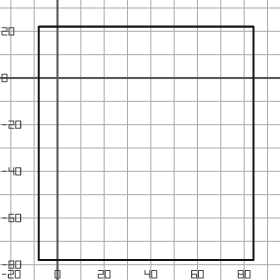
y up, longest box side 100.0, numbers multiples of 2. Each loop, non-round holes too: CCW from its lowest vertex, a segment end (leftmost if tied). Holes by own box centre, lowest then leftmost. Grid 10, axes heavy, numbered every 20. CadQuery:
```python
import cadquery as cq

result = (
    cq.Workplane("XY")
    .moveTo(-8.0, -78.0)
    .lineTo(84.0, -78.0)
    .lineTo(84.0, 22.0)
    .lineTo(-8.0, 22.0)
    .close()
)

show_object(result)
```